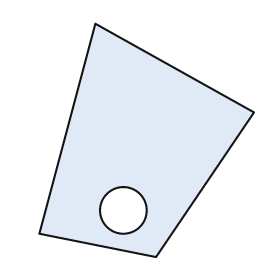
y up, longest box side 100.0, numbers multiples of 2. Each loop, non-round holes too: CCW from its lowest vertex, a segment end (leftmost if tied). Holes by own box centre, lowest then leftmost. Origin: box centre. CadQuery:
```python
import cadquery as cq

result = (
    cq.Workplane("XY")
    .moveTo(4.0, -50.0)
    .lineTo(46.0, 12.0)
    .lineTo(-22.0, 50.0)
    .lineTo(-46.0, -40.0)
    .close()
    .moveTo(-10.0, -30.0)
    .circle(10.0)
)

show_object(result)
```